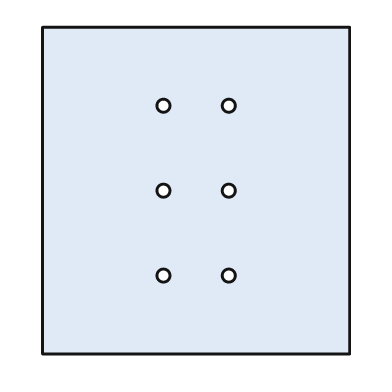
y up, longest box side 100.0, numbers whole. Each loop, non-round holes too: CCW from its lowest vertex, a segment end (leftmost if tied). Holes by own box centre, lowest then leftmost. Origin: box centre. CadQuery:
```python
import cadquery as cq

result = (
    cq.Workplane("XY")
    .moveTo(-47.0, -50.0)
    .lineTo(47.0, -50.0)
    .lineTo(47.0, 50.0)
    .lineTo(-47.0, 50.0)
    .close()
    .moveTo(-10.0, -26.0)
    .circle(2.0)
    .moveTo(10.0, -26.0)
    .circle(2.0)
    .moveTo(-10.0, 0.0)
    .circle(2.0)
    .moveTo(10.0, 0.0)
    .circle(2.0)
    .moveTo(-10.0, 26.0)
    .circle(2.0)
    .moveTo(10.0, 26.0)
    .circle(2.0)
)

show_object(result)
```